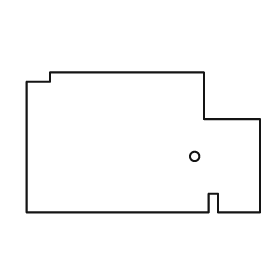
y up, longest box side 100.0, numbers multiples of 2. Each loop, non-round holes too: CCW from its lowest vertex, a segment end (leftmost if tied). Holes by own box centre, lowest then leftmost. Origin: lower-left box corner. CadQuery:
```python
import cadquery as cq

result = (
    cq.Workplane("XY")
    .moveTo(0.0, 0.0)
    .lineTo(78.0, 0.0)
    .lineTo(78.0, 8.0)
    .lineTo(82.0, 8.0)
    .lineTo(82.0, 0.0)
    .lineTo(100.0, 0.0)
    .lineTo(100.0, 40.0)
    .lineTo(76.0, 40.0)
    .lineTo(76.0, 60.0)
    .lineTo(10.0, 60.0)
    .lineTo(10.0, 56.0)
    .lineTo(0.0, 56.0)
    .close()
    .moveTo(72.0, 24.0)
    .circle(2.0)
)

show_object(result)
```